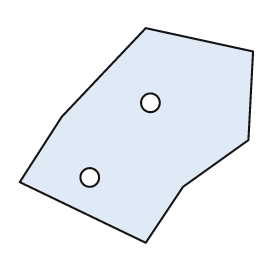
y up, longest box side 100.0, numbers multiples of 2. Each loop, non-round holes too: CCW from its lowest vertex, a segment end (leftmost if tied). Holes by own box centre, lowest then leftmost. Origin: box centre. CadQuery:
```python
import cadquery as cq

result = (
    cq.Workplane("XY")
    .moveTo(4.0, -46.0)
    .lineTo(20.0, -22.0)
    .lineTo(48.0, -2.0)
    .lineTo(50.0, 36.0)
    .lineTo(4.0, 46.0)
    .lineTo(-32.0, 8.0)
    .lineTo(-50.0, -20.0)
    .close()
    .moveTo(-20.0, -18.0)
    .circle(4.0)
    .moveTo(6.0, 14.0)
    .circle(4.0)
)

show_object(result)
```